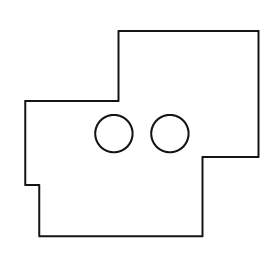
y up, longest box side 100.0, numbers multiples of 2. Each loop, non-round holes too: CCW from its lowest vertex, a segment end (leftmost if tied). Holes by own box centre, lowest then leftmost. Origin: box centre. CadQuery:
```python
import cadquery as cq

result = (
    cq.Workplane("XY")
    .moveTo(-44.0, -44.0)
    .lineTo(26.0, -44.0)
    .lineTo(26.0, -10.0)
    .lineTo(50.0, -10.0)
    .lineTo(50.0, 44.0)
    .lineTo(-10.0, 44.0)
    .lineTo(-10.0, 14.0)
    .lineTo(-50.0, 14.0)
    .lineTo(-50.0, -22.0)
    .lineTo(-44.0, -22.0)
    .close()
    .moveTo(-12.0, 0.0)
    .circle(8.0)
    .moveTo(12.0, 0.0)
    .circle(8.0)
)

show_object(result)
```